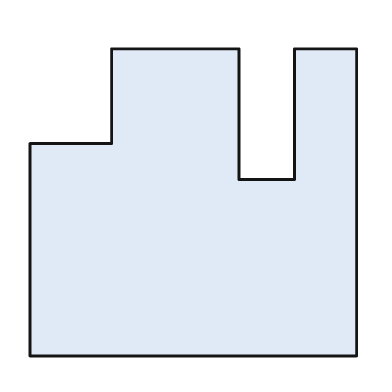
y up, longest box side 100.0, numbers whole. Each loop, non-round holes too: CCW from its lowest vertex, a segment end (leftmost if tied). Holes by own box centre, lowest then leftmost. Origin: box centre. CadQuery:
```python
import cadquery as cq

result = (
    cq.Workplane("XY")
    .moveTo(-50.0, -47.0)
    .lineTo(50.0, -47.0)
    .lineTo(50.0, 47.0)
    .lineTo(31.0, 47.0)
    .lineTo(31.0, 7.0)
    .lineTo(14.0, 7.0)
    .lineTo(14.0, 47.0)
    .lineTo(-25.0, 47.0)
    .lineTo(-25.0, 18.0)
    .lineTo(-50.0, 18.0)
    .close()
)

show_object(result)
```